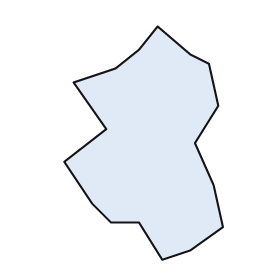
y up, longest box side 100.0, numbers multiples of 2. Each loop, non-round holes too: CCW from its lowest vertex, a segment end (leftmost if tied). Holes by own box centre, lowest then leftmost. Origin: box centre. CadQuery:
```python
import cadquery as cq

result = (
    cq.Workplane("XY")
    .moveTo(8.0, -50.0)
    .lineTo(20.0, -46.0)
    .lineTo(34.0, -36.0)
    .lineTo(30.0, -18.0)
    .lineTo(22.0, 0.0)
    .lineTo(32.0, 16.0)
    .lineTo(28.0, 34.0)
    .lineTo(20.0, 38.0)
    .lineTo(6.0, 50.0)
    .lineTo(-2.0, 40.0)
    .lineTo(-12.0, 32.0)
    .lineTo(-30.0, 26.0)
    .lineTo(-16.0, 6.0)
    .lineTo(-34.0, -8.0)
    .lineTo(-22.0, -26.0)
    .lineTo(-14.0, -34.0)
    .lineTo(-2.0, -34.0)
    .close()
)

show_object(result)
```